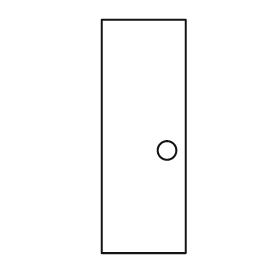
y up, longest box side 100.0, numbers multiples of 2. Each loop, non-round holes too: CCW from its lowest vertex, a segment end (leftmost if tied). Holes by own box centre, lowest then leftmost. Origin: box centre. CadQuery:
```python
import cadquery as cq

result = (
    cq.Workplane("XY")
    .moveTo(-18.0, -50.0)
    .lineTo(18.0, -50.0)
    .lineTo(18.0, 50.0)
    .lineTo(-18.0, 50.0)
    .close()
    .moveTo(10.0, -6.0)
    .circle(4.0)
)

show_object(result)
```